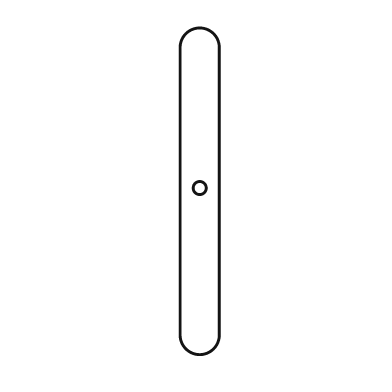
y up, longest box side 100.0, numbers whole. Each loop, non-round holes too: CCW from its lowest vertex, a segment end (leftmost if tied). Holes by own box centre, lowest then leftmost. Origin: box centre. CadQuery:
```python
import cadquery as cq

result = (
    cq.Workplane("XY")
    .moveTo(-6.0, -44.0)
    .threePointArc((0.0, -50.0), (6.0, -44.0))
    .lineTo(6.0, 44.0)
    .threePointArc((0.0, 50.0), (-6.0, 44.0))
    .close()
    .moveTo(0.0, 1.0)
    .circle(2.0)
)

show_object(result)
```